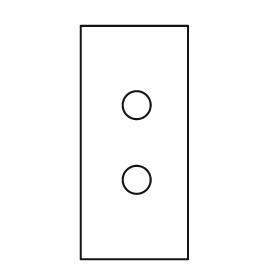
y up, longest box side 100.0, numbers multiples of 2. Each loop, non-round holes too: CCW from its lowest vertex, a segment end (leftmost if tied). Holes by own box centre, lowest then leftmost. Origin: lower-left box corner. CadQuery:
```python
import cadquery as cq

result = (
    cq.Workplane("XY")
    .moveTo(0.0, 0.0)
    .lineTo(46.0, 0.0)
    .lineTo(46.0, 100.0)
    .lineTo(0.0, 100.0)
    .close()
    .moveTo(24.0, 34.0)
    .circle(6.0)
    .moveTo(24.0, 66.0)
    .circle(6.0)
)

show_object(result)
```